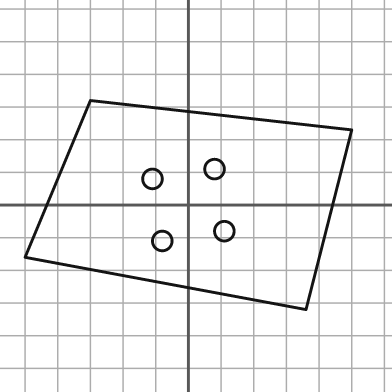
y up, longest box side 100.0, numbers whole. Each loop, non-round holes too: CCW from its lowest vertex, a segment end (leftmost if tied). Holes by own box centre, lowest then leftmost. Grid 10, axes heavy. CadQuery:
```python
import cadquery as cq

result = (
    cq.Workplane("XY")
    .moveTo(36.0, -32.0)
    .lineTo(50.0, 23.0)
    .lineTo(-30.0, 32.0)
    .lineTo(-50.0, -16.0)
    .close()
    .moveTo(-8.0, -11.0)
    .circle(3.0)
    .moveTo(11.0, -8.0)
    .circle(3.0)
    .moveTo(-11.0, 8.0)
    .circle(3.0)
    .moveTo(8.0, 11.0)
    .circle(3.0)
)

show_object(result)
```